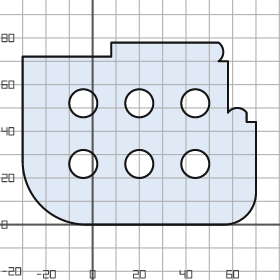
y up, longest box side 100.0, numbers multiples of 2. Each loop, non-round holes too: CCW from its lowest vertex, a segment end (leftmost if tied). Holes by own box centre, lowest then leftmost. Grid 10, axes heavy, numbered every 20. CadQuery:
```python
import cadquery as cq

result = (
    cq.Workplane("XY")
    .moveTo(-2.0, 0.0)
    .lineTo(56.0, 0.0)
    .threePointArc((66.0, 4.0), (70.0, 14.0))
    .lineTo(70.0, 44.0)
    .lineTo(66.0, 44.0)
    .lineTo(66.0, 48.0)
    .threePointArc((62.0, 50.0), (58.0, 48.0))
    .lineTo(58.0, 70.0)
    .lineTo(54.0, 70.0)
    .threePointArc((56.0, 74.0), (54.0, 78.0))
    .lineTo(8.0, 78.0)
    .lineTo(8.0, 72.0)
    .lineTo(-30.0, 72.0)
    .lineTo(-30.0, 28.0)
    .threePointArc((-22.0, 8.0), (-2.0, 0.0))
    .close()
    .moveTo(-4.0, 26.0)
    .circle(6.0)
    .moveTo(20.0, 26.0)
    .circle(6.0)
    .moveTo(44.0, 26.0)
    .circle(6.0)
    .moveTo(-4.0, 52.0)
    .circle(6.0)
    .moveTo(20.0, 52.0)
    .circle(6.0)
    .moveTo(44.0, 52.0)
    .circle(6.0)
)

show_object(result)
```